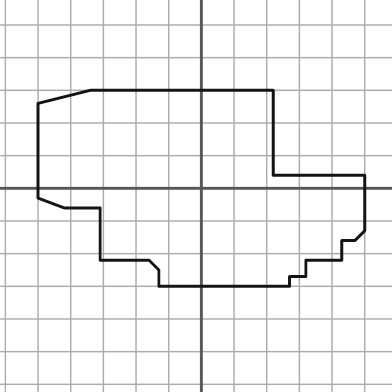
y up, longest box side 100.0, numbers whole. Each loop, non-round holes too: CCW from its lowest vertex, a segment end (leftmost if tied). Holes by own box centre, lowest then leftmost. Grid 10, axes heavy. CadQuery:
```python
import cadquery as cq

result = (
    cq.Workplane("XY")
    .moveTo(-13.0, -30.0)
    .lineTo(27.0, -30.0)
    .lineTo(27.0, -27.0)
    .lineTo(32.0, -27.0)
    .lineTo(32.0, -22.0)
    .lineTo(43.0, -22.0)
    .lineTo(43.0, -16.0)
    .lineTo(47.0, -16.0)
    .lineTo(50.0, -13.0)
    .lineTo(50.0, 4.0)
    .lineTo(22.0, 4.0)
    .lineTo(22.0, 30.0)
    .lineTo(-34.0, 30.0)
    .lineTo(-50.0, 26.0)
    .lineTo(-50.0, -3.0)
    .lineTo(-42.0, -6.0)
    .lineTo(-31.0, -6.0)
    .lineTo(-31.0, -22.0)
    .lineTo(-16.0, -22.0)
    .lineTo(-13.0, -25.0)
    .close()
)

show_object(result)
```